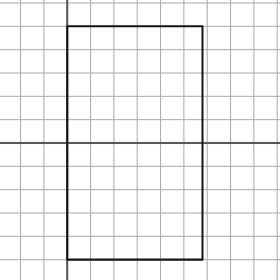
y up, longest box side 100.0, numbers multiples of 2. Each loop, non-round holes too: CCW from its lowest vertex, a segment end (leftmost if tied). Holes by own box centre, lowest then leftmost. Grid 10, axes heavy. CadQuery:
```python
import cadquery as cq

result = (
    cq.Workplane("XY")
    .moveTo(0.0, -50.0)
    .lineTo(58.0, -50.0)
    .lineTo(58.0, 50.0)
    .lineTo(0.0, 50.0)
    .close()
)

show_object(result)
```